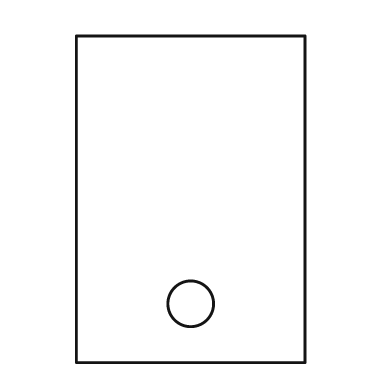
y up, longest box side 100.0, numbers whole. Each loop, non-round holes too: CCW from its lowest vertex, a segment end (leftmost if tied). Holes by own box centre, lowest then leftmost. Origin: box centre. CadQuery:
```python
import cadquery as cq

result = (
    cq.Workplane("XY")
    .moveTo(-35.0, -50.0)
    .lineTo(35.0, -50.0)
    .lineTo(35.0, 50.0)
    .lineTo(-35.0, 50.0)
    .close()
    .moveTo(0.0, -32.0)
    .circle(7.0)
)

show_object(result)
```